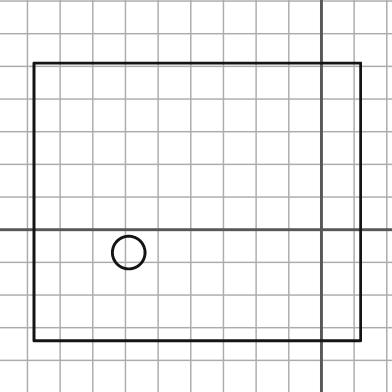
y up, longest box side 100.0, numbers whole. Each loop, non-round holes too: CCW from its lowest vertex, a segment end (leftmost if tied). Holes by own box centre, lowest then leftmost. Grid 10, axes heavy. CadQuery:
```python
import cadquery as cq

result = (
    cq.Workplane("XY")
    .moveTo(-88.0, -34.0)
    .lineTo(12.0, -34.0)
    .lineTo(12.0, 51.0)
    .lineTo(-88.0, 51.0)
    .close()
    .moveTo(-59.0, -7.0)
    .circle(5.0)
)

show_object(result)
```